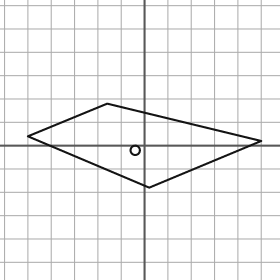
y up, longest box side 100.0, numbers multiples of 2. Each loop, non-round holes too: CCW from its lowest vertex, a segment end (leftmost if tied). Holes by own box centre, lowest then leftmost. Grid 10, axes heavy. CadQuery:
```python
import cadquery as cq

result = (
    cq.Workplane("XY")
    .moveTo(2.0, -18.0)
    .lineTo(50.0, 2.0)
    .lineTo(-16.0, 18.0)
    .lineTo(-50.0, 4.0)
    .close()
    .moveTo(-4.0, -2.0)
    .circle(2.0)
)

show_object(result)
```